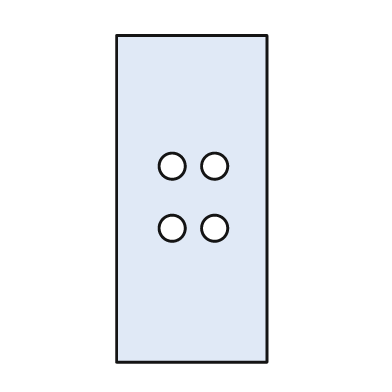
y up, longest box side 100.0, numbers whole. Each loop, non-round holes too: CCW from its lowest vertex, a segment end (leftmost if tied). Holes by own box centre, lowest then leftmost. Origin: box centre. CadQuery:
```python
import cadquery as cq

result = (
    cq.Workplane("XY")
    .moveTo(-23.0, -50.0)
    .lineTo(23.0, -50.0)
    .lineTo(23.0, 50.0)
    .lineTo(-23.0, 50.0)
    .close()
    .moveTo(-6.0, -9.0)
    .circle(4.0)
    .moveTo(7.0, -9.0)
    .circle(4.0)
    .moveTo(-6.0, 10.0)
    .circle(4.0)
    .moveTo(7.0, 10.0)
    .circle(4.0)
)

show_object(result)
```